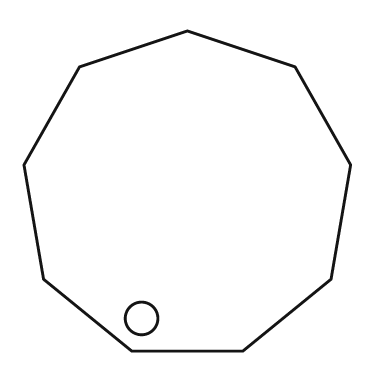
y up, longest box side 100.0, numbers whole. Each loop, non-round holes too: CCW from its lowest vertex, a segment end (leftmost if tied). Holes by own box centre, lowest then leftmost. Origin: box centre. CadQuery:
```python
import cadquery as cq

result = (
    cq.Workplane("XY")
    .moveTo(-17.0, -49.0)
    .lineTo(17.0, -49.0)
    .lineTo(44.0, -27.0)
    .lineTo(50.0, 8.0)
    .lineTo(33.0, 38.0)
    .lineTo(0.0, 49.0)
    .lineTo(-33.0, 38.0)
    .lineTo(-50.0, 8.0)
    .lineTo(-44.0, -27.0)
    .close()
    .moveTo(-14.0, -39.0)
    .circle(5.0)
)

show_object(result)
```